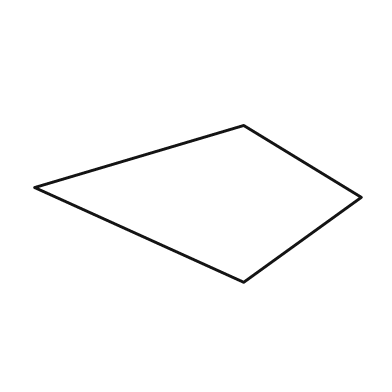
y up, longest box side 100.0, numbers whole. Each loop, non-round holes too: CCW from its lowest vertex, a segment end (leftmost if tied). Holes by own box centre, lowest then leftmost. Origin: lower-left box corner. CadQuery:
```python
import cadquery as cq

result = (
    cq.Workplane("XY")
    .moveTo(64.0, 0.0)
    .lineTo(100.0, 26.0)
    .lineTo(64.0, 48.0)
    .lineTo(0.0, 29.0)
    .close()
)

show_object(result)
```